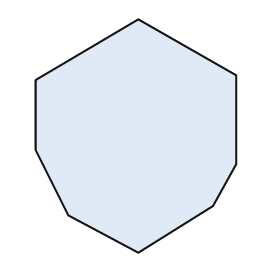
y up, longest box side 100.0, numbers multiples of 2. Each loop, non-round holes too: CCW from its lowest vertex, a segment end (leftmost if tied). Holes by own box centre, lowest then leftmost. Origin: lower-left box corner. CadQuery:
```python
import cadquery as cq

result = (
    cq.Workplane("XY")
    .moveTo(44.0, 0.0)
    .lineTo(76.0, 20.0)
    .lineTo(86.0, 38.0)
    .lineTo(86.0, 76.0)
    .lineTo(44.0, 100.0)
    .lineTo(0.0, 74.0)
    .lineTo(0.0, 44.0)
    .lineTo(14.0, 16.0)
    .close()
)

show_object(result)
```